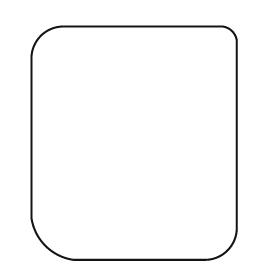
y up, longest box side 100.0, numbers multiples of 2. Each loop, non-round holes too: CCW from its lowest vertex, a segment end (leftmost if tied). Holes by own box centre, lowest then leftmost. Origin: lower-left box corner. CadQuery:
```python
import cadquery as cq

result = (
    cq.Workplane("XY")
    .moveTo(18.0, 0.0)
    .lineTo(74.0, 0.0)
    .threePointArc((84.0, 4.0), (88.0, 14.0))
    .lineTo(88.0, 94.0)
    .threePointArc((86.0, 98.0), (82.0, 100.0))
    .lineTo(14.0, 100.0)
    .threePointArc((4.0, 96.0), (0.0, 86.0))
    .lineTo(0.0, 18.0)
    .threePointArc((6.0, 6.0), (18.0, 0.0))
    .close()
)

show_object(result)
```